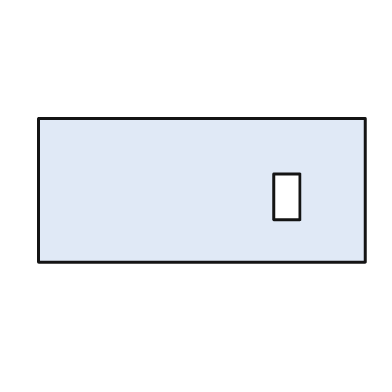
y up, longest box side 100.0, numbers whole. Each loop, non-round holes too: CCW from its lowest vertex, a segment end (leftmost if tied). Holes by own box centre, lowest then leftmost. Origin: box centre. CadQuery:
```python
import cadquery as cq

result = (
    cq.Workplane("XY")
    .moveTo(-50.0, -22.0)
    .lineTo(50.0, -22.0)
    .lineTo(50.0, 22.0)
    .lineTo(-50.0, 22.0)
    .close()
    .moveTo(22.0, -9.0)
    .lineTo(30.0, -9.0)
    .lineTo(30.0, 5.0)
    .lineTo(22.0, 5.0)
    .close()
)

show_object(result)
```